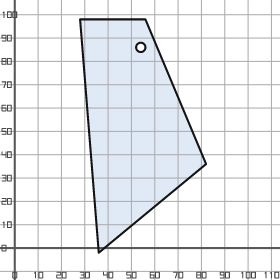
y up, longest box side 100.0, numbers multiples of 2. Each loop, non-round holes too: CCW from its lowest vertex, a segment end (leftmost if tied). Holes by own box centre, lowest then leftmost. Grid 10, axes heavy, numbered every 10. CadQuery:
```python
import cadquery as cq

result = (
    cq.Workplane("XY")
    .moveTo(36.0, -2.0)
    .lineTo(82.0, 36.0)
    .lineTo(56.0, 98.0)
    .lineTo(28.0, 98.0)
    .close()
    .moveTo(54.0, 86.0)
    .circle(2.0)
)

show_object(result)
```